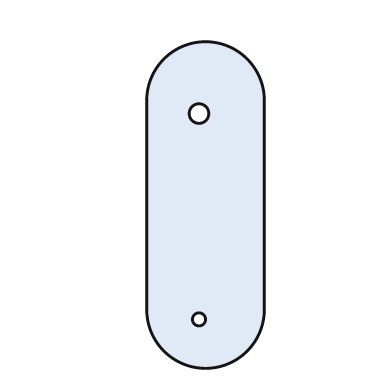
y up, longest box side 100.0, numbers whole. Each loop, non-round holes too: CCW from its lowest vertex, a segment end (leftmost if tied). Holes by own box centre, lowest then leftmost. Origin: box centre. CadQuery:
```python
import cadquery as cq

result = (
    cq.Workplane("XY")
    .moveTo(-18.0, -32.0)
    .threePointArc((0.0, -50.0), (18.0, -32.0))
    .lineTo(18.0, 32.0)
    .threePointArc((0.0, 50.0), (-18.0, 32.0))
    .close()
    .moveTo(-2.0, -35.0)
    .circle(2.0)
    .moveTo(-2.0, 28.0)
    .circle(3.0)
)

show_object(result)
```